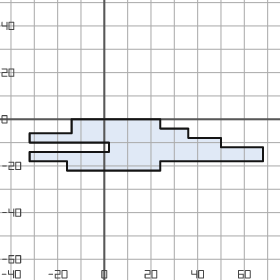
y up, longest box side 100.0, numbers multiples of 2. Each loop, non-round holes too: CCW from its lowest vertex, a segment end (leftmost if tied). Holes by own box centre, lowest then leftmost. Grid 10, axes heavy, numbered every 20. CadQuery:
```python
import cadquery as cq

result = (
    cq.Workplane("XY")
    .moveTo(-16.0, -22.0)
    .lineTo(24.0, -22.0)
    .lineTo(24.0, -18.0)
    .lineTo(68.0, -18.0)
    .lineTo(68.0, -12.0)
    .lineTo(50.0, -12.0)
    .lineTo(50.0, -8.0)
    .lineTo(36.0, -8.0)
    .lineTo(36.0, -4.0)
    .lineTo(24.0, -4.0)
    .lineTo(24.0, 0.0)
    .lineTo(-14.0, 0.0)
    .lineTo(-14.0, -6.0)
    .lineTo(-32.0, -6.0)
    .lineTo(-32.0, -10.0)
    .lineTo(2.0, -10.0)
    .lineTo(2.0, -14.0)
    .lineTo(-32.0, -14.0)
    .lineTo(-32.0, -18.0)
    .lineTo(-16.0, -18.0)
    .close()
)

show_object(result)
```